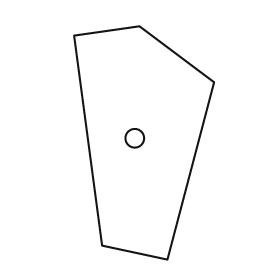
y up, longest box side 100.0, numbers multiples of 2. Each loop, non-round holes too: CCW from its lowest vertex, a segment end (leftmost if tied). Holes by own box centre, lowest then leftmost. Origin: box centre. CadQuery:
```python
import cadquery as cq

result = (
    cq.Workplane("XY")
    .moveTo(10.0, -50.0)
    .lineTo(30.0, 26.0)
    .lineTo(-2.0, 50.0)
    .lineTo(-30.0, 46.0)
    .lineTo(-18.0, -44.0)
    .close()
    .moveTo(-4.0, 2.0)
    .circle(4.0)
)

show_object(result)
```